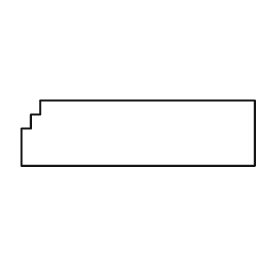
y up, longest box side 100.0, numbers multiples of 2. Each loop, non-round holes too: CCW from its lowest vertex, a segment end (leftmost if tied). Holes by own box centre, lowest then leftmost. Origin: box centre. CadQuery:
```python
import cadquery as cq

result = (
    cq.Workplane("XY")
    .moveTo(-50.0, -14.0)
    .lineTo(50.0, -14.0)
    .lineTo(50.0, 14.0)
    .lineTo(-42.0, 14.0)
    .lineTo(-42.0, 8.0)
    .lineTo(-46.0, 8.0)
    .lineTo(-46.0, 2.0)
    .lineTo(-50.0, 2.0)
    .close()
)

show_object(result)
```